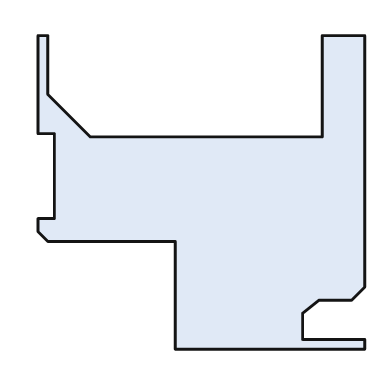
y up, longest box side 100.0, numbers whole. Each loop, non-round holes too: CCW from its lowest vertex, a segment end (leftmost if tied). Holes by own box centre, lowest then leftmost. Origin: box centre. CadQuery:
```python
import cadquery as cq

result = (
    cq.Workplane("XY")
    .moveTo(-8.0, -48.0)
    .lineTo(50.0, -48.0)
    .lineTo(50.0, -45.0)
    .lineTo(31.0, -45.0)
    .lineTo(31.0, -37.0)
    .lineTo(36.0, -33.0)
    .lineTo(46.0, -33.0)
    .lineTo(50.0, -29.0)
    .lineTo(50.0, 48.0)
    .lineTo(37.0, 48.0)
    .lineTo(37.0, 17.0)
    .lineTo(-34.0, 17.0)
    .lineTo(-47.0, 30.0)
    .lineTo(-47.0, 48.0)
    .lineTo(-50.0, 48.0)
    .lineTo(-50.0, 18.0)
    .lineTo(-45.0, 18.0)
    .lineTo(-45.0, -8.0)
    .lineTo(-50.0, -8.0)
    .lineTo(-50.0, -12.0)
    .lineTo(-47.0, -15.0)
    .lineTo(-8.0, -15.0)
    .close()
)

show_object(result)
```